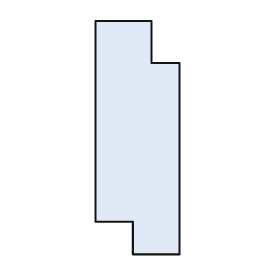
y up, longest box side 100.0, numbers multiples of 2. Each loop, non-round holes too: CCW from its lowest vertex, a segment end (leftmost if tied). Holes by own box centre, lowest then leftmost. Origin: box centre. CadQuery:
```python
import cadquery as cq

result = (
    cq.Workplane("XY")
    .moveTo(-2.0, -50.0)
    .lineTo(18.0, -50.0)
    .lineTo(18.0, 32.0)
    .lineTo(6.0, 32.0)
    .lineTo(6.0, 50.0)
    .lineTo(-18.0, 50.0)
    .lineTo(-18.0, -36.0)
    .lineTo(-2.0, -36.0)
    .close()
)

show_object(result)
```